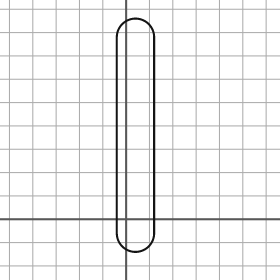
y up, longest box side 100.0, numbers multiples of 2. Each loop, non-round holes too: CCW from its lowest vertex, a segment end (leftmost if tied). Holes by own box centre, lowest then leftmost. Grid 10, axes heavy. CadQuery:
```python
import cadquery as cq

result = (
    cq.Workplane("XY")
    .moveTo(-4.0, -6.0)
    .threePointArc((4.0, -14.0), (12.0, -6.0))
    .lineTo(12.0, 78.0)
    .threePointArc((4.0, 86.0), (-4.0, 78.0))
    .close()
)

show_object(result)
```